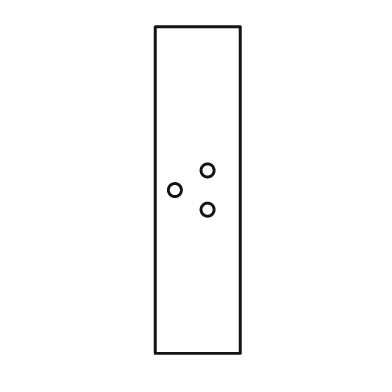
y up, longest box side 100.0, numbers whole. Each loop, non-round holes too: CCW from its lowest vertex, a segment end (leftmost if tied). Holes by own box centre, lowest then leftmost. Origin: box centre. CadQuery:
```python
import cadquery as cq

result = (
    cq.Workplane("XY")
    .moveTo(-13.0, -50.0)
    .lineTo(13.0, -50.0)
    .lineTo(13.0, 50.0)
    .lineTo(-13.0, 50.0)
    .close()
    .moveTo(3.0, -6.0)
    .circle(2.0)
    .moveTo(-7.0, 0.0)
    .circle(2.0)
    .moveTo(3.0, 6.0)
    .circle(2.0)
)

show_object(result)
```